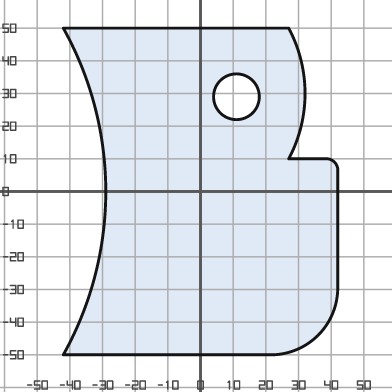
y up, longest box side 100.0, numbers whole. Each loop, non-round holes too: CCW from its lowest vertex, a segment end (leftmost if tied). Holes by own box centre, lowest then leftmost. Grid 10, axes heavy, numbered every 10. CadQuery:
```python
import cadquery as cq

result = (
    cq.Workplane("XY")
    .moveTo(-42.0, -50.0)
    .lineTo(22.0, -50.0)
    .threePointArc((36.0, -44.0), (42.0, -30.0))
    .lineTo(42.0, 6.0)
    .threePointArc((41.0, 9.0), (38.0, 10.0))
    .lineTo(27.0, 10.0)
    .threePointArc((32.0, 30.0), (27.0, 50.0))
    .lineTo(-42.0, 50.0)
    .threePointArc((-29.0, 0.0), (-42.0, -50.0))
    .close()
    .moveTo(11.0, 29.0)
    .circle(7.0)
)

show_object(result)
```